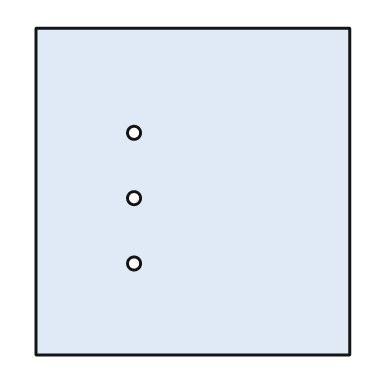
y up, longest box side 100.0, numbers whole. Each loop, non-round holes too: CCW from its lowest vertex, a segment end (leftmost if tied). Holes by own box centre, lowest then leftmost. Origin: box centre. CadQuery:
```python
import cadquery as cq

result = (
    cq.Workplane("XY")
    .moveTo(-48.0, -50.0)
    .lineTo(48.0, -50.0)
    .lineTo(48.0, 50.0)
    .lineTo(-48.0, 50.0)
    .close()
    .moveTo(-18.0, -22.0)
    .circle(2.0)
    .moveTo(-18.0, -2.0)
    .circle(2.0)
    .moveTo(-18.0, 18.0)
    .circle(2.0)
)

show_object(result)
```